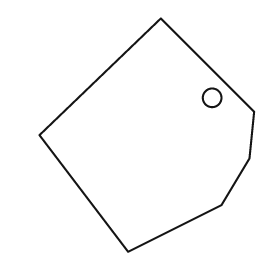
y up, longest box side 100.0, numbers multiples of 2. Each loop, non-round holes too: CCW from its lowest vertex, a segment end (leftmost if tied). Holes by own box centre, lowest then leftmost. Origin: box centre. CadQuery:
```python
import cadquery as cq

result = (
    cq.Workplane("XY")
    .moveTo(-8.0, -50.0)
    .lineTo(32.0, -30.0)
    .lineTo(44.0, -10.0)
    .lineTo(46.0, 10.0)
    .lineTo(6.0, 50.0)
    .lineTo(-46.0, 0.0)
    .close()
    .moveTo(28.0, 16.0)
    .circle(4.0)
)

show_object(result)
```